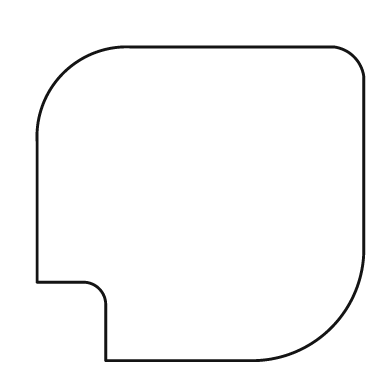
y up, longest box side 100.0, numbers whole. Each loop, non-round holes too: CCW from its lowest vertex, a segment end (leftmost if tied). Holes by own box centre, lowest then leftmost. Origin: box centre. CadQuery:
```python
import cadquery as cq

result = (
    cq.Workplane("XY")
    .moveTo(-29.0, -48.0)
    .lineTo(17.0, -48.0)
    .threePointArc((40.0, -38.0), (50.0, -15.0))
    .lineTo(50.0, 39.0)
    .threePointArc((47.0, 45.0), (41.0, 48.0))
    .lineTo(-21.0, 48.0)
    .threePointArc((-42.0, 40.0), (-50.0, 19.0))
    .lineTo(-50.0, -24.0)
    .lineTo(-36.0, -24.0)
    .threePointArc((-31.0, -26.0), (-29.0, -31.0))
    .close()
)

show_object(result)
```